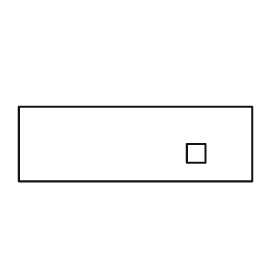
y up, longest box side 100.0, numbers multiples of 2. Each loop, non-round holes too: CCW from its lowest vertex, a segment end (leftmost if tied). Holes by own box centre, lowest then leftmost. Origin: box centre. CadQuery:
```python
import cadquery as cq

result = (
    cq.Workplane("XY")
    .moveTo(-50.0, -16.0)
    .lineTo(50.0, -16.0)
    .lineTo(50.0, 16.0)
    .lineTo(-50.0, 16.0)
    .close()
    .moveTo(22.0, -8.0)
    .lineTo(30.0, -8.0)
    .lineTo(30.0, 0.0)
    .lineTo(22.0, 0.0)
    .close()
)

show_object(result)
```